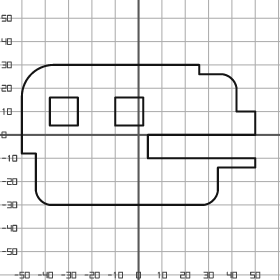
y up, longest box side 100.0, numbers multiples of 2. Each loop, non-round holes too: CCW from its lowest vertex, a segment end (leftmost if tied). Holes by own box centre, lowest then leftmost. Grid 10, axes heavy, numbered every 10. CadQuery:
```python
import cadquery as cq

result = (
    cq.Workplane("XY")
    .moveTo(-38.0, -30.0)
    .lineTo(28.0, -30.0)
    .threePointArc((32.0, -28.0), (34.0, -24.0))
    .lineTo(34.0, -14.0)
    .lineTo(50.0, -14.0)
    .lineTo(50.0, -10.0)
    .lineTo(4.0, -10.0)
    .lineTo(4.0, 0.0)
    .lineTo(50.0, 0.0)
    .lineTo(50.0, 10.0)
    .lineTo(42.0, 10.0)
    .lineTo(42.0, 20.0)
    .threePointArc((40.0, 24.0), (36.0, 26.0))
    .lineTo(26.0, 26.0)
    .lineTo(26.0, 30.0)
    .lineTo(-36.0, 30.0)
    .threePointArc((-46.0, 26.0), (-50.0, 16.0))
    .lineTo(-50.0, -8.0)
    .lineTo(-44.0, -8.0)
    .lineTo(-44.0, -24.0)
    .threePointArc((-42.0, -28.0), (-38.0, -30.0))
    .close()
    .moveTo(-38.0, 4.0)
    .lineTo(-26.0, 4.0)
    .lineTo(-26.0, 16.0)
    .lineTo(-38.0, 16.0)
    .close()
    .moveTo(-10.0, 4.0)
    .lineTo(2.0, 4.0)
    .lineTo(2.0, 16.0)
    .lineTo(-10.0, 16.0)
    .close()
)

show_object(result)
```